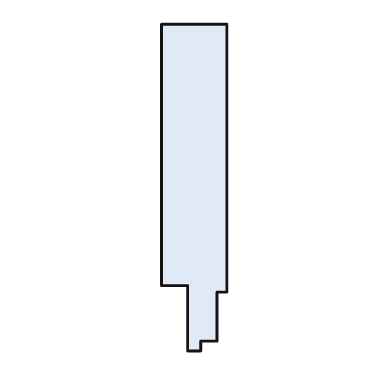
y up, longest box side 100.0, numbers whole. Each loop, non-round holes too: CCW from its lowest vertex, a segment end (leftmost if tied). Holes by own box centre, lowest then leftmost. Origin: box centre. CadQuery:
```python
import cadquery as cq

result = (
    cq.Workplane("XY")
    .moveTo(-2.0, -50.0)
    .lineTo(2.0, -50.0)
    .lineTo(2.0, -47.0)
    .lineTo(7.0, -47.0)
    .lineTo(7.0, -32.0)
    .lineTo(10.0, -32.0)
    .lineTo(10.0, 50.0)
    .lineTo(-10.0, 50.0)
    .lineTo(-10.0, -30.0)
    .lineTo(-2.0, -30.0)
    .close()
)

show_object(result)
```